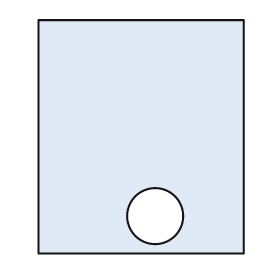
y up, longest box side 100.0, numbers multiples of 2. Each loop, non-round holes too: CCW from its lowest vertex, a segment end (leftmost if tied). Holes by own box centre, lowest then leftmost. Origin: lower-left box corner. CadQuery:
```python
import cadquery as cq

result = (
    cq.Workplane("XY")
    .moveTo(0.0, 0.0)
    .lineTo(88.0, 0.0)
    .lineTo(88.0, 100.0)
    .lineTo(0.0, 100.0)
    .close()
    .moveTo(50.0, 16.0)
    .circle(12.0)
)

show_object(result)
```